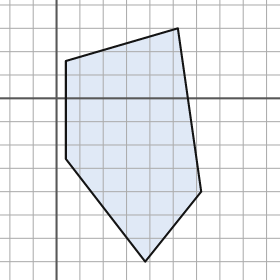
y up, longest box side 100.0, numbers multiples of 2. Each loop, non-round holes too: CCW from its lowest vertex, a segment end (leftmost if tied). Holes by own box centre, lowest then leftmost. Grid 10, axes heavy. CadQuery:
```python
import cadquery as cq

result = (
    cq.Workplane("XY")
    .moveTo(38.0, -70.0)
    .lineTo(62.0, -40.0)
    .lineTo(52.0, 30.0)
    .lineTo(4.0, 16.0)
    .lineTo(4.0, -26.0)
    .close()
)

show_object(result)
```